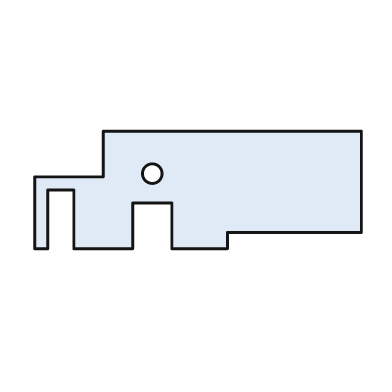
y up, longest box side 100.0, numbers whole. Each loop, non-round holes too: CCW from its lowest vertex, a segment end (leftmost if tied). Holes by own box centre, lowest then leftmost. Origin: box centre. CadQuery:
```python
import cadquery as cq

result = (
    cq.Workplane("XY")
    .moveTo(-50.0, -18.0)
    .lineTo(-46.0, -18.0)
    .lineTo(-46.0, 0.0)
    .lineTo(-38.0, 0.0)
    .lineTo(-38.0, -18.0)
    .lineTo(-20.0, -18.0)
    .lineTo(-20.0, -4.0)
    .lineTo(-8.0, -4.0)
    .lineTo(-8.0, -18.0)
    .lineTo(9.0, -18.0)
    .lineTo(9.0, -13.0)
    .lineTo(50.0, -13.0)
    .lineTo(50.0, 18.0)
    .lineTo(-29.0, 18.0)
    .lineTo(-29.0, 4.0)
    .lineTo(-50.0, 4.0)
    .close()
    .moveTo(-14.0, 5.0)
    .circle(3.0)
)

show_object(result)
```